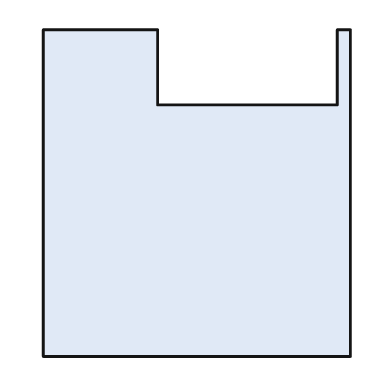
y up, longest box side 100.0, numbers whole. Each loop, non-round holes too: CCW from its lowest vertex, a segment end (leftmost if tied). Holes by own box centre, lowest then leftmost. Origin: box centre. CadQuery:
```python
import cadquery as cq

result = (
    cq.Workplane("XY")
    .moveTo(-47.0, -50.0)
    .lineTo(47.0, -50.0)
    .lineTo(47.0, 50.0)
    .lineTo(43.0, 50.0)
    .lineTo(43.0, 27.0)
    .lineTo(-12.0, 27.0)
    .lineTo(-12.0, 50.0)
    .lineTo(-47.0, 50.0)
    .close()
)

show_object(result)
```